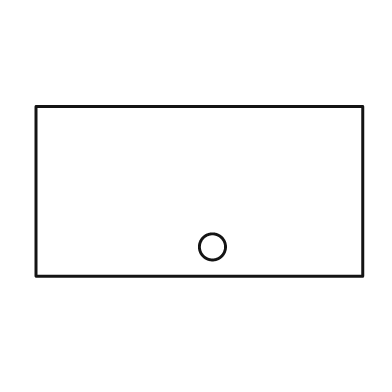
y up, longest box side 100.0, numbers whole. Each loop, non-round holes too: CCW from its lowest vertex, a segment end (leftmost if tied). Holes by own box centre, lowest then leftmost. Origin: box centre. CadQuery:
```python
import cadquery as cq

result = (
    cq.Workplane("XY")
    .moveTo(-50.0, -26.0)
    .lineTo(50.0, -26.0)
    .lineTo(50.0, 26.0)
    .lineTo(-50.0, 26.0)
    .close()
    .moveTo(4.0, -17.0)
    .circle(4.0)
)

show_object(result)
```